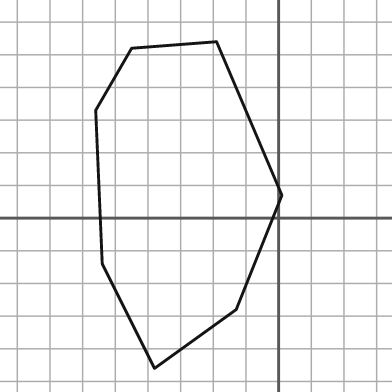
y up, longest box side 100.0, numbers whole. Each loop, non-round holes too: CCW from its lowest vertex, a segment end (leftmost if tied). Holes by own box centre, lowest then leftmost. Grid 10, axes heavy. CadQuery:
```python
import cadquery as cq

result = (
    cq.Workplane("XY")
    .moveTo(-38.0, -46.0)
    .lineTo(-13.0, -28.0)
    .lineTo(1.0, 7.0)
    .lineTo(-19.0, 54.0)
    .lineTo(-45.0, 52.0)
    .lineTo(-56.0, 33.0)
    .lineTo(-54.0, -14.0)
    .close()
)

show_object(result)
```